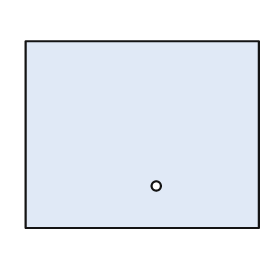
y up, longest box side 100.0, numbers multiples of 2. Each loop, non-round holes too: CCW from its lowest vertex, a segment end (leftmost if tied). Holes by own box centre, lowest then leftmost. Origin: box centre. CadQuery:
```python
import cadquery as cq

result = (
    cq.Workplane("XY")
    .moveTo(-50.0, -40.0)
    .lineTo(50.0, -40.0)
    .lineTo(50.0, 40.0)
    .lineTo(-50.0, 40.0)
    .close()
    .moveTo(6.0, -22.0)
    .circle(2.0)
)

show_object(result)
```